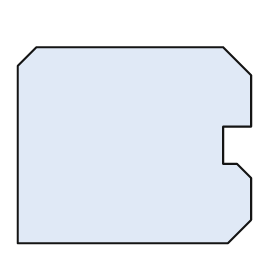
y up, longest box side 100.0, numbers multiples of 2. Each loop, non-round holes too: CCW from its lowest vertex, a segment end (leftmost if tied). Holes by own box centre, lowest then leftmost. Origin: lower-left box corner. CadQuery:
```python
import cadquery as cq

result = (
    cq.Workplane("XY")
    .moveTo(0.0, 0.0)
    .lineTo(90.0, 0.0)
    .lineTo(100.0, 10.0)
    .lineTo(100.0, 28.0)
    .lineTo(94.0, 34.0)
    .lineTo(88.0, 34.0)
    .lineTo(88.0, 50.0)
    .lineTo(100.0, 50.0)
    .lineTo(100.0, 72.0)
    .lineTo(88.0, 84.0)
    .lineTo(8.0, 84.0)
    .lineTo(0.0, 76.0)
    .close()
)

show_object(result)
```